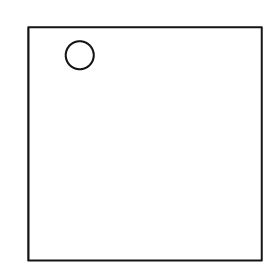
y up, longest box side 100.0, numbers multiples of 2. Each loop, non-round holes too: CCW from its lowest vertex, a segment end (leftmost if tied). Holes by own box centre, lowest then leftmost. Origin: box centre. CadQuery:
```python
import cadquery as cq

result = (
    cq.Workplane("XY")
    .moveTo(-50.0, -50.0)
    .lineTo(50.0, -50.0)
    .lineTo(50.0, 50.0)
    .lineTo(-50.0, 50.0)
    .close()
    .moveTo(-28.0, 38.0)
    .circle(6.0)
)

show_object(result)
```